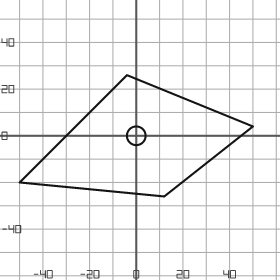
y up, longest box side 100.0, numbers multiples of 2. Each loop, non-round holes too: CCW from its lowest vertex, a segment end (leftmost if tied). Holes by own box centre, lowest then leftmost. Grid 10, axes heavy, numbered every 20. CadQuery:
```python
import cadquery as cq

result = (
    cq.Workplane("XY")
    .moveTo(12.0, -26.0)
    .lineTo(50.0, 4.0)
    .lineTo(-4.0, 26.0)
    .lineTo(-50.0, -20.0)
    .close()
    .moveTo(0.0, 0.0)
    .circle(4.0)
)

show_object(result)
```